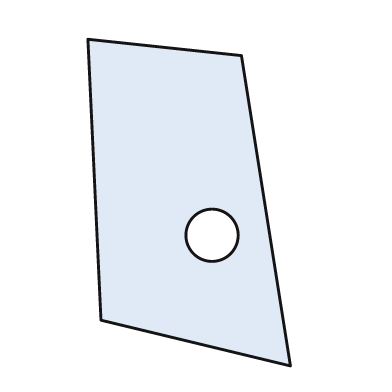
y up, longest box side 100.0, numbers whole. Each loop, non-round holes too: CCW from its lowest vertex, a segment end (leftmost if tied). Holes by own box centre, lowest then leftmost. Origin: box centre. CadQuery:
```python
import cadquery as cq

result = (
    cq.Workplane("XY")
    .moveTo(31.0, -50.0)
    .lineTo(16.0, 45.0)
    .lineTo(-31.0, 50.0)
    .lineTo(-27.0, -36.0)
    .close()
    .moveTo(7.0, -10.0)
    .circle(8.0)
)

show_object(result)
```